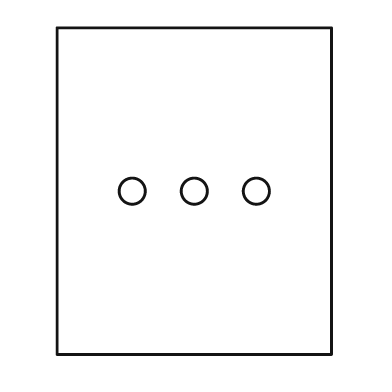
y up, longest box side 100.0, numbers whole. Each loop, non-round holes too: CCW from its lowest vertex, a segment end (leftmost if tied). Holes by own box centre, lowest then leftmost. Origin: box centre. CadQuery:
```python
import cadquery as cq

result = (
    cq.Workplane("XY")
    .moveTo(-42.0, -50.0)
    .lineTo(42.0, -50.0)
    .lineTo(42.0, 50.0)
    .lineTo(-42.0, 50.0)
    .close()
    .moveTo(-19.0, 0.0)
    .circle(4.0)
    .moveTo(0.0, 0.0)
    .circle(4.0)
    .moveTo(19.0, 0.0)
    .circle(4.0)
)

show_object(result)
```